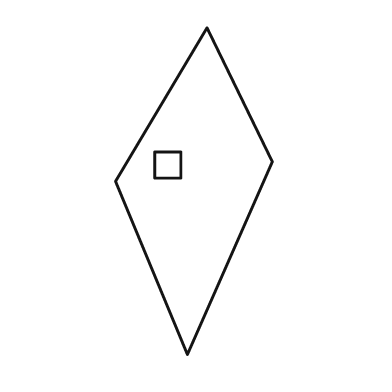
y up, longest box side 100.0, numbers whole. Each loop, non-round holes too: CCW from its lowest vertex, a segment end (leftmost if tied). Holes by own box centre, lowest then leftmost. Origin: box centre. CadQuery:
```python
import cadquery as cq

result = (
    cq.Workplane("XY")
    .moveTo(-2.0, -50.0)
    .lineTo(24.0, 9.0)
    .lineTo(4.0, 50.0)
    .lineTo(-24.0, 3.0)
    .close()
    .moveTo(-12.0, 4.0)
    .lineTo(-4.0, 4.0)
    .lineTo(-4.0, 12.0)
    .lineTo(-12.0, 12.0)
    .close()
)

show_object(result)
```